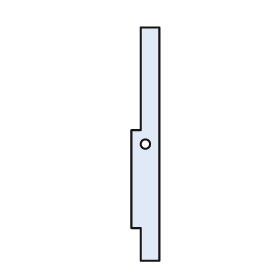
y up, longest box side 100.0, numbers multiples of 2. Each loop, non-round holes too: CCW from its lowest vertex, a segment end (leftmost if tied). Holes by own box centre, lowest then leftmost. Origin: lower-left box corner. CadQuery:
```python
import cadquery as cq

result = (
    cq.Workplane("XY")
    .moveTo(4.0, 0.0)
    .lineTo(12.0, 0.0)
    .lineTo(12.0, 100.0)
    .lineTo(4.0, 100.0)
    .lineTo(4.0, 56.0)
    .lineTo(0.0, 56.0)
    .lineTo(0.0, 14.0)
    .lineTo(4.0, 14.0)
    .close()
    .moveTo(6.0, 50.0)
    .circle(2.0)
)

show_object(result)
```